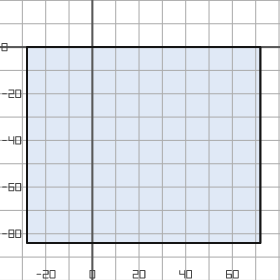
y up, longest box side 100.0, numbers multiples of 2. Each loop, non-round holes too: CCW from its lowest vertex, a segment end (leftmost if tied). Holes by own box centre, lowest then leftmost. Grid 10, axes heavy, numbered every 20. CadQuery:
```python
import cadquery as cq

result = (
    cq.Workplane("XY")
    .moveTo(-28.0, -84.0)
    .lineTo(72.0, -84.0)
    .lineTo(72.0, 0.0)
    .lineTo(-28.0, 0.0)
    .close()
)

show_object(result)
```